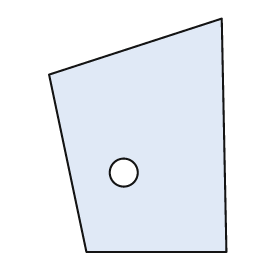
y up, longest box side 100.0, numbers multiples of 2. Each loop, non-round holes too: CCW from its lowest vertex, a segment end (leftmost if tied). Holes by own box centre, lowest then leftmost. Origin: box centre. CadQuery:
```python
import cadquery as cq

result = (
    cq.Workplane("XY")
    .moveTo(-22.0, -50.0)
    .lineTo(38.0, -50.0)
    .lineTo(36.0, 50.0)
    .lineTo(-38.0, 26.0)
    .close()
    .moveTo(-6.0, -16.0)
    .circle(6.0)
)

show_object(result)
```